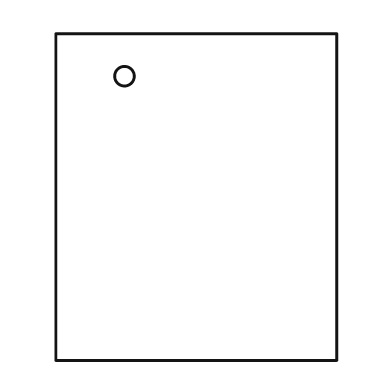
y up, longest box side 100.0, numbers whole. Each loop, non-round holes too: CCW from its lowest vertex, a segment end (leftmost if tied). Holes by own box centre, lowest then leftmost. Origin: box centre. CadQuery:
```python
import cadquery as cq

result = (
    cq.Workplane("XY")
    .moveTo(-43.0, -50.0)
    .lineTo(43.0, -50.0)
    .lineTo(43.0, 50.0)
    .lineTo(-43.0, 50.0)
    .close()
    .moveTo(-22.0, 37.0)
    .circle(3.0)
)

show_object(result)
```